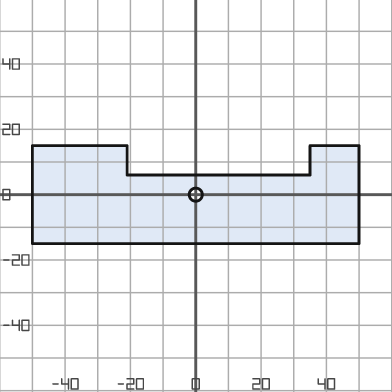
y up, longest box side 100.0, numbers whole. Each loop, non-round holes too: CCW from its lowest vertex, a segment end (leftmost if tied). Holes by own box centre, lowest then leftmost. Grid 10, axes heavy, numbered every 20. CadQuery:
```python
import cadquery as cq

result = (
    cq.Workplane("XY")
    .moveTo(-50.0, -15.0)
    .lineTo(50.0, -15.0)
    .lineTo(50.0, 15.0)
    .lineTo(35.0, 15.0)
    .lineTo(35.0, 6.0)
    .lineTo(-21.0, 6.0)
    .lineTo(-21.0, 15.0)
    .lineTo(-50.0, 15.0)
    .close()
    .moveTo(0.0, 0.0)
    .circle(2.0)
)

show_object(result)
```